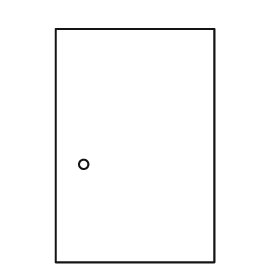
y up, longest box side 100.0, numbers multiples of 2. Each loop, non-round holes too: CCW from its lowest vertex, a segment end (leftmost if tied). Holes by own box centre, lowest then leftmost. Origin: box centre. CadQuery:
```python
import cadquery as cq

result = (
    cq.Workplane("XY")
    .moveTo(-34.0, -50.0)
    .lineTo(34.0, -50.0)
    .lineTo(34.0, 50.0)
    .lineTo(-34.0, 50.0)
    .close()
    .moveTo(-22.0, -8.0)
    .circle(2.0)
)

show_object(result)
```